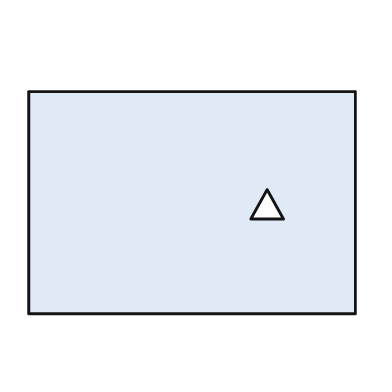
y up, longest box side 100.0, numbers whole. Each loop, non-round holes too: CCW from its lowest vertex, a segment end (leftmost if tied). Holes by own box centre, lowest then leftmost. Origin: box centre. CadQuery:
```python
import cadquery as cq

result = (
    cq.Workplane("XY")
    .moveTo(-50.0, -34.0)
    .lineTo(50.0, -34.0)
    .lineTo(50.0, 34.0)
    .lineTo(-50.0, 34.0)
    .close()
    .moveTo(18.0, -5.0)
    .lineTo(28.0, -5.0)
    .lineTo(23.0, 4.0)
    .close()
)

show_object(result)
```